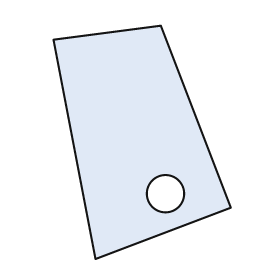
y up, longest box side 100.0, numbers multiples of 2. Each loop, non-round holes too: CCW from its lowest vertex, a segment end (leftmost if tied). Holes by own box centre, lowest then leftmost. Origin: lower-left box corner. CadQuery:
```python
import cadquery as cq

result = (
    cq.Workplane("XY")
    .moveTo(18.0, 0.0)
    .lineTo(76.0, 22.0)
    .lineTo(46.0, 100.0)
    .lineTo(0.0, 94.0)
    .close()
    .moveTo(48.0, 28.0)
    .circle(8.0)
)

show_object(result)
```